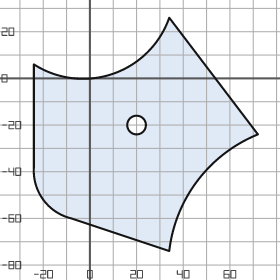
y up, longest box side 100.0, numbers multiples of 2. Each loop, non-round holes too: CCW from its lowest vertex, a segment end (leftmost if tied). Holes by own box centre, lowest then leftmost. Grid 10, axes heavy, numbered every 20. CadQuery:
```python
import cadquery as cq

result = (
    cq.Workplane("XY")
    .moveTo(34.0, -74.0)
    .threePointArc((46.0, -44.0), (72.0, -24.0))
    .lineTo(34.0, 26.0)
    .threePointArc((10.0, 2.0), (-24.0, 6.0))
    .lineTo(-24.0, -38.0)
    .threePointArc((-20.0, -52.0), (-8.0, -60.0))
    .close()
    .moveTo(20.0, -20.0)
    .circle(4.0)
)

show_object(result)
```